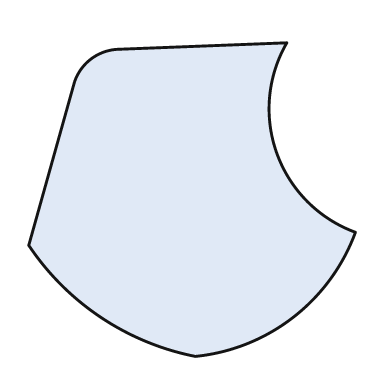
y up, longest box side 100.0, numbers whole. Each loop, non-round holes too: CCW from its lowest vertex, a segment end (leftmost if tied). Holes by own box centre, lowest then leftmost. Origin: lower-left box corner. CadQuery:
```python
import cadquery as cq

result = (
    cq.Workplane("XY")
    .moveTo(51.0, 0.0)
    .threePointArc((81.0, 12.0), (100.0, 38.0))
    .threePointArc((76.0, 62.0), (79.0, 96.0))
    .lineTo(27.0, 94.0)
    .threePointArc((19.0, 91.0), (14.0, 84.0))
    .lineTo(0.0, 34.0)
    .threePointArc((22.0, 12.0), (51.0, 0.0))
    .close()
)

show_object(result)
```